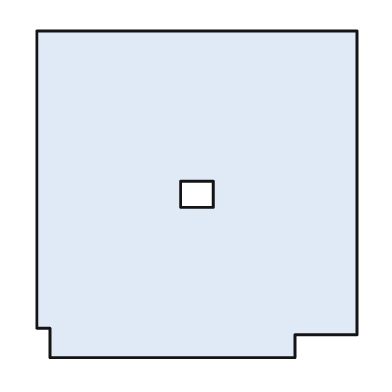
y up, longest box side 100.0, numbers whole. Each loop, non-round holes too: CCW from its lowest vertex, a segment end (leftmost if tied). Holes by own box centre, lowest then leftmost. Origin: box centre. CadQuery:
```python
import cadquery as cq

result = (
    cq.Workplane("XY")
    .moveTo(-45.0, -50.0)
    .lineTo(30.0, -50.0)
    .lineTo(30.0, -43.0)
    .lineTo(49.0, -43.0)
    .lineTo(49.0, 50.0)
    .lineTo(-49.0, 50.0)
    .lineTo(-49.0, -41.0)
    .lineTo(-45.0, -41.0)
    .close()
    .moveTo(-5.0, -4.0)
    .lineTo(5.0, -4.0)
    .lineTo(5.0, 4.0)
    .lineTo(-5.0, 4.0)
    .close()
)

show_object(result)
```